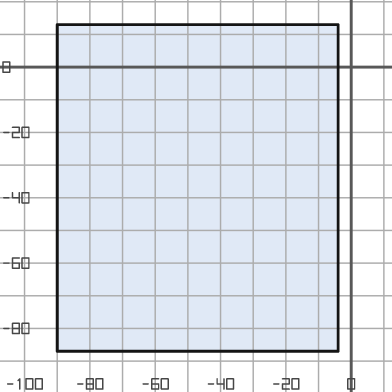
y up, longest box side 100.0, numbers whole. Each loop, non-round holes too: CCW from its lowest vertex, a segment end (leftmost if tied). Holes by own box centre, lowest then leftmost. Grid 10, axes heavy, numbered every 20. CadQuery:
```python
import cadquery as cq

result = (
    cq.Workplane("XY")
    .moveTo(-90.0, -87.0)
    .lineTo(-4.0, -87.0)
    .lineTo(-4.0, 13.0)
    .lineTo(-90.0, 13.0)
    .close()
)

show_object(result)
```